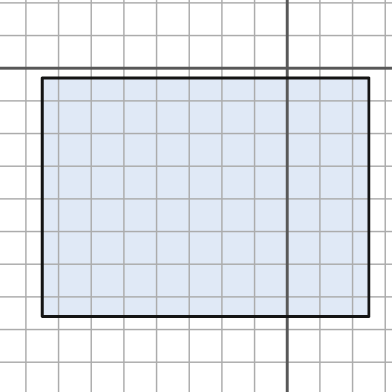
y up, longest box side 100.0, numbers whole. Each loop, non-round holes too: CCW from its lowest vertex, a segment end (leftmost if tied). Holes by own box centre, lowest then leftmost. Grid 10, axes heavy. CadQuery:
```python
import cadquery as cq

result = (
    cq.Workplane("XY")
    .moveTo(-75.0, -76.0)
    .lineTo(25.0, -76.0)
    .lineTo(25.0, -3.0)
    .lineTo(-75.0, -3.0)
    .close()
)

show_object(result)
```